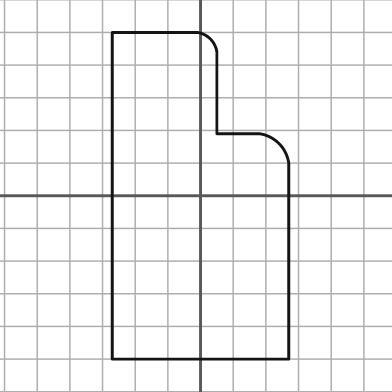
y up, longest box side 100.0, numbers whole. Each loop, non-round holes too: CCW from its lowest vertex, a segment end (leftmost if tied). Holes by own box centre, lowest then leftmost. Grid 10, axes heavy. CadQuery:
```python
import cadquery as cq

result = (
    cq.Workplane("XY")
    .moveTo(-27.0, -50.0)
    .lineTo(27.0, -50.0)
    .lineTo(27.0, 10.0)
    .threePointArc((24.0, 16.0), (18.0, 19.0))
    .lineTo(5.0, 19.0)
    .lineTo(5.0, 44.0)
    .threePointArc((3.0, 48.0), (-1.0, 50.0))
    .lineTo(-27.0, 50.0)
    .close()
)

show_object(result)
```